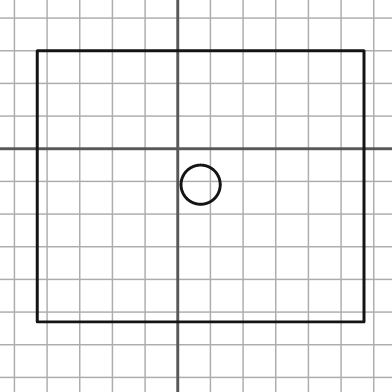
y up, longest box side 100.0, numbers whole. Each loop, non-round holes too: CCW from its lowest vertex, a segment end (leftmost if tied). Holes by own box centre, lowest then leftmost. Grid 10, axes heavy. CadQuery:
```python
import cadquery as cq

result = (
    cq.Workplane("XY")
    .moveTo(-43.0, -53.0)
    .lineTo(57.0, -53.0)
    .lineTo(57.0, 30.0)
    .lineTo(-43.0, 30.0)
    .close()
    .moveTo(7.0, -11.0)
    .circle(6.0)
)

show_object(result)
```